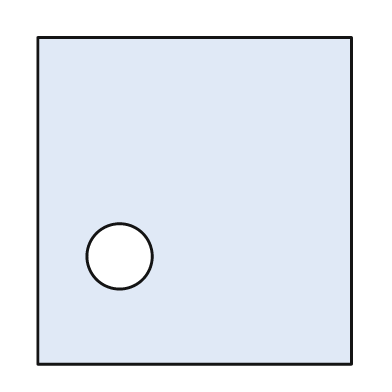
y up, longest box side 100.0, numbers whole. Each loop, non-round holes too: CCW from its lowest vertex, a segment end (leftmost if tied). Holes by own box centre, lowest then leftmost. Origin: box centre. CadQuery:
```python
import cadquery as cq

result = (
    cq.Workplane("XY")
    .moveTo(-48.0, -50.0)
    .lineTo(48.0, -50.0)
    .lineTo(48.0, 50.0)
    .lineTo(-48.0, 50.0)
    .close()
    .moveTo(-23.0, -17.0)
    .circle(10.0)
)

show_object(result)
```